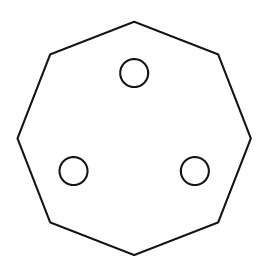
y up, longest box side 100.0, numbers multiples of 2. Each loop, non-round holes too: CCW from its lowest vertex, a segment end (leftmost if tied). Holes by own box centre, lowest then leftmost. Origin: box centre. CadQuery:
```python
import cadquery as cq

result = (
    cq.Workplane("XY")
    .moveTo(0.0, -50.0)
    .lineTo(36.0, -36.0)
    .lineTo(50.0, 0.0)
    .lineTo(36.0, 36.0)
    .lineTo(0.0, 50.0)
    .lineTo(-36.0, 36.0)
    .lineTo(-50.0, 0.0)
    .lineTo(-36.0, -36.0)
    .close()
    .moveTo(-26.0, -14.0)
    .circle(6.0)
    .moveTo(26.0, -14.0)
    .circle(6.0)
    .moveTo(0.0, 28.0)
    .circle(6.0)
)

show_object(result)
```